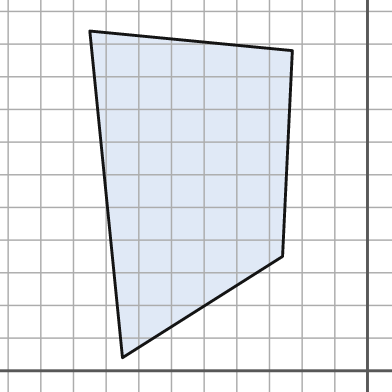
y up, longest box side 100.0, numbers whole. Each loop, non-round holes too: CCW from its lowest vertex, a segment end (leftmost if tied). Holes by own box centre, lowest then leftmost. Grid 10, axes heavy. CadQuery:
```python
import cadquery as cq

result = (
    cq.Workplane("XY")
    .moveTo(-75.0, 4.0)
    .lineTo(-26.0, 35.0)
    .lineTo(-23.0, 98.0)
    .lineTo(-85.0, 104.0)
    .close()
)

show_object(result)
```